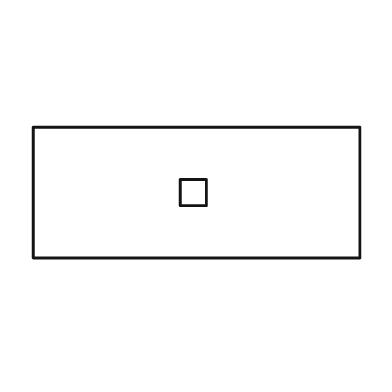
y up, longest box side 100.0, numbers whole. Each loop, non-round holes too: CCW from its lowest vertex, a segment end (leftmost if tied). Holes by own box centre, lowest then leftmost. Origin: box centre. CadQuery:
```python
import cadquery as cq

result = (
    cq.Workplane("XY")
    .moveTo(-50.0, -20.0)
    .lineTo(50.0, -20.0)
    .lineTo(50.0, 20.0)
    .lineTo(-50.0, 20.0)
    .close()
    .moveTo(-5.0, -4.0)
    .lineTo(3.0, -4.0)
    .lineTo(3.0, 4.0)
    .lineTo(-5.0, 4.0)
    .close()
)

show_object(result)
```